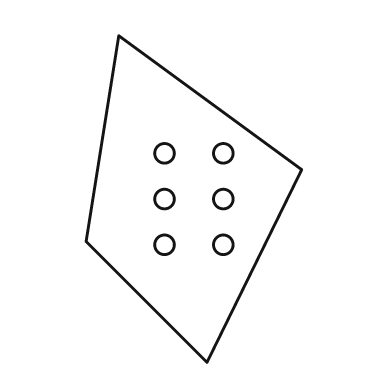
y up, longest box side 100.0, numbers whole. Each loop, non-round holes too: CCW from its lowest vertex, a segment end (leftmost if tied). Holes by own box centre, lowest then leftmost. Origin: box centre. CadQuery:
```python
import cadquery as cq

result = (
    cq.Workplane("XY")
    .moveTo(4.0, -50.0)
    .lineTo(33.0, 9.0)
    .lineTo(-23.0, 50.0)
    .lineTo(-33.0, -13.0)
    .close()
    .moveTo(-9.0, -14.0)
    .circle(3.0)
    .moveTo(9.0, -14.0)
    .circle(3.0)
    .moveTo(-9.0, 0.0)
    .circle(3.0)
    .moveTo(9.0, 0.0)
    .circle(3.0)
    .moveTo(-9.0, 14.0)
    .circle(3.0)
    .moveTo(9.0, 14.0)
    .circle(3.0)
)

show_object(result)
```